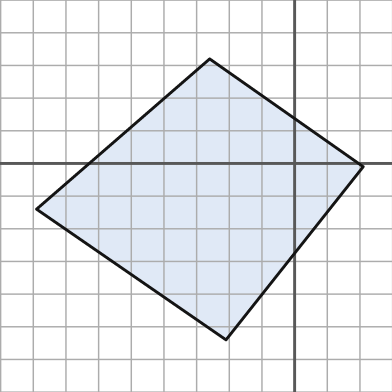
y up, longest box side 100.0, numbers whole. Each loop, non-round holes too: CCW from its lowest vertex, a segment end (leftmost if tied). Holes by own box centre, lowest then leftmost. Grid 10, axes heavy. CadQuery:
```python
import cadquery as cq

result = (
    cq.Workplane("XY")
    .moveTo(-21.0, -54.0)
    .lineTo(21.0, -1.0)
    .lineTo(-26.0, 32.0)
    .lineTo(-79.0, -14.0)
    .close()
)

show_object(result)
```